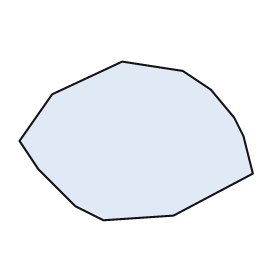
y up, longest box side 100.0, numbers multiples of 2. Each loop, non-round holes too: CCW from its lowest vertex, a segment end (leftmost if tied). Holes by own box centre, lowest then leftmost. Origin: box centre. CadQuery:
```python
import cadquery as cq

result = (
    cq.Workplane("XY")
    .moveTo(-14.0, -34.0)
    .lineTo(16.0, -32.0)
    .lineTo(50.0, -14.0)
    .lineTo(46.0, 2.0)
    .lineTo(42.0, 10.0)
    .lineTo(32.0, 22.0)
    .lineTo(20.0, 30.0)
    .lineTo(-6.0, 34.0)
    .lineTo(-36.0, 20.0)
    .lineTo(-50.0, 0.0)
    .lineTo(-42.0, -12.0)
    .lineTo(-26.0, -28.0)
    .close()
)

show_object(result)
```